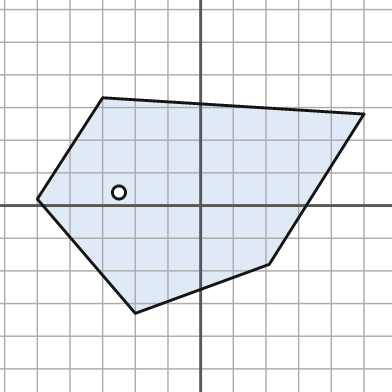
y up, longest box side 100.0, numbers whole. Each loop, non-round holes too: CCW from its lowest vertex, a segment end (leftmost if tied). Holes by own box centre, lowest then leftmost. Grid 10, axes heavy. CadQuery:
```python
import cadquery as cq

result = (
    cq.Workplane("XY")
    .moveTo(-20.0, -33.0)
    .lineTo(21.0, -18.0)
    .lineTo(50.0, 28.0)
    .lineTo(-30.0, 33.0)
    .lineTo(-50.0, 2.0)
    .close()
    .moveTo(-25.0, 4.0)
    .circle(2.0)
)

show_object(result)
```